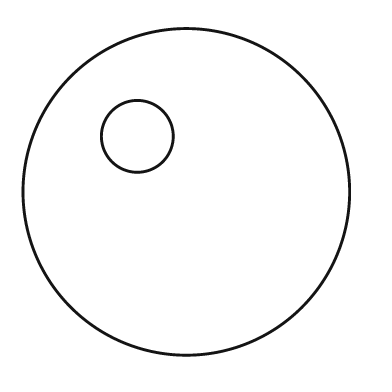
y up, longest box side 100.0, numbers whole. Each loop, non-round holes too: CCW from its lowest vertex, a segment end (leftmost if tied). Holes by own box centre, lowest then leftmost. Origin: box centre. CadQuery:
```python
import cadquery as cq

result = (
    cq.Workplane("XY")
    .moveTo(0.0, 0.0)
    .circle(50.0)
    .moveTo(-15.0, 17.0)
    .circle(11.0)
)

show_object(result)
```